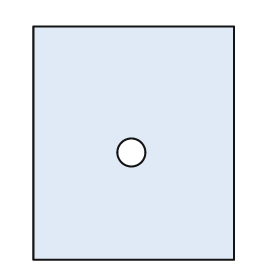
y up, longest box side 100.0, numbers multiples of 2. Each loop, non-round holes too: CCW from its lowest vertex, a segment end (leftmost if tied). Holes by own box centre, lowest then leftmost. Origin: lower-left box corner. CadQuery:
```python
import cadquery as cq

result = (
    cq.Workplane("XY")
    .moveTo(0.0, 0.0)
    .lineTo(86.0, 0.0)
    .lineTo(86.0, 100.0)
    .lineTo(0.0, 100.0)
    .close()
    .moveTo(42.0, 46.0)
    .circle(6.0)
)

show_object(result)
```